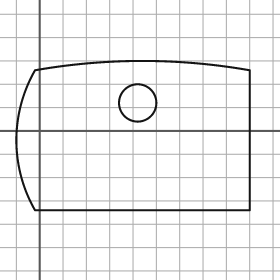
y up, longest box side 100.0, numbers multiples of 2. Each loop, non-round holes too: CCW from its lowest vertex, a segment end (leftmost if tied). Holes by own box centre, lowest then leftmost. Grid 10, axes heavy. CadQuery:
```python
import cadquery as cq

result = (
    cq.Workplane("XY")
    .moveTo(-2.0, -34.0)
    .lineTo(90.0, -34.0)
    .lineTo(90.0, 26.0)
    .threePointArc((44.0, 30.0), (-2.0, 26.0))
    .threePointArc((-10.0, -4.0), (-2.0, -34.0))
    .close()
    .moveTo(42.0, 12.0)
    .circle(8.0)
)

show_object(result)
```